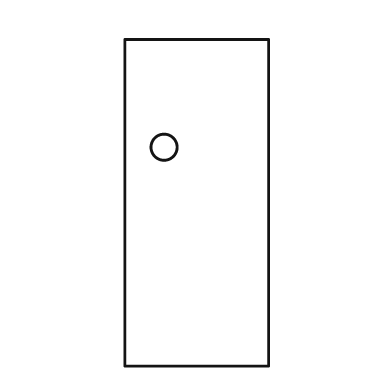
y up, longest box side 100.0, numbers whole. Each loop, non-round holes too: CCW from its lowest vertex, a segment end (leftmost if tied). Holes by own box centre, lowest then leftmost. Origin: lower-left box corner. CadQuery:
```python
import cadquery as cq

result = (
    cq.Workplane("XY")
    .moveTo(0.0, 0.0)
    .lineTo(44.0, 0.0)
    .lineTo(44.0, 100.0)
    .lineTo(0.0, 100.0)
    .close()
    .moveTo(12.0, 67.0)
    .circle(4.0)
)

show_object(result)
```